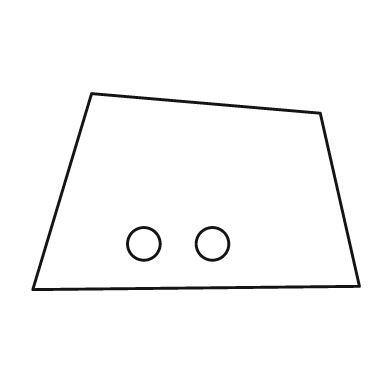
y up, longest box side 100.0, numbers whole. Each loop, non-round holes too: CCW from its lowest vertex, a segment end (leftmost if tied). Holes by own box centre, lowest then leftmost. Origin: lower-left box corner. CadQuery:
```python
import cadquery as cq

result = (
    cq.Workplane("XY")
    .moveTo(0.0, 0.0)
    .lineTo(100.0, 1.0)
    .lineTo(88.0, 54.0)
    .lineTo(18.0, 60.0)
    .close()
    .moveTo(34.0, 14.0)
    .circle(5.0)
    .moveTo(55.0, 14.0)
    .circle(5.0)
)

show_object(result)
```